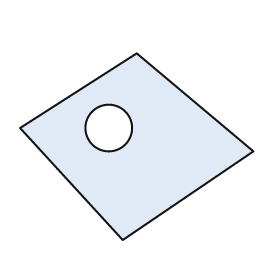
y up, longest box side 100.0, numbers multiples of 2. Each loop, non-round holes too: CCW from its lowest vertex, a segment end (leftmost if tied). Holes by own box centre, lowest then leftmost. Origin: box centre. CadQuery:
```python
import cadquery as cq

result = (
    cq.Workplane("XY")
    .moveTo(-6.0, -40.0)
    .lineTo(50.0, -2.0)
    .lineTo(0.0, 40.0)
    .lineTo(-50.0, 8.0)
    .close()
    .moveTo(-12.0, 8.0)
    .circle(10.0)
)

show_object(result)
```